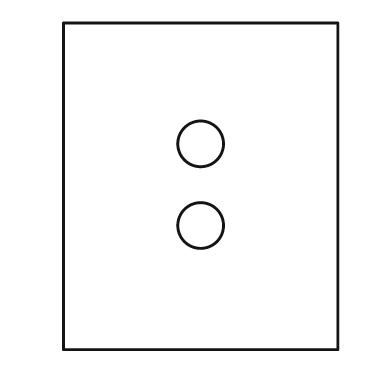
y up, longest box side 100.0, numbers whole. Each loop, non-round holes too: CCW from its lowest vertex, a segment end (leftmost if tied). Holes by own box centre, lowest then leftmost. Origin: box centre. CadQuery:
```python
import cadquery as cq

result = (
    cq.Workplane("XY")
    .moveTo(-42.0, -50.0)
    .lineTo(42.0, -50.0)
    .lineTo(42.0, 50.0)
    .lineTo(-42.0, 50.0)
    .close()
    .moveTo(0.0, -12.0)
    .circle(7.0)
    .moveTo(0.0, 13.0)
    .circle(7.0)
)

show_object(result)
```